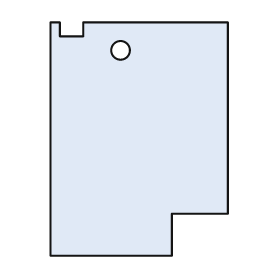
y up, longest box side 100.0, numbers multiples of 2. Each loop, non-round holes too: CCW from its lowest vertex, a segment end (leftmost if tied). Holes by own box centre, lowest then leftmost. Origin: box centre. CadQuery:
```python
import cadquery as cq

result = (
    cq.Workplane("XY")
    .moveTo(-38.0, -50.0)
    .lineTo(14.0, -50.0)
    .lineTo(14.0, -32.0)
    .lineTo(38.0, -32.0)
    .lineTo(38.0, 50.0)
    .lineTo(-24.0, 50.0)
    .lineTo(-24.0, 44.0)
    .lineTo(-34.0, 44.0)
    .lineTo(-34.0, 50.0)
    .lineTo(-38.0, 50.0)
    .close()
    .moveTo(-8.0, 38.0)
    .circle(4.0)
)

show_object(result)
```